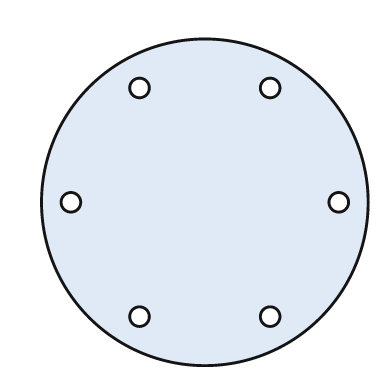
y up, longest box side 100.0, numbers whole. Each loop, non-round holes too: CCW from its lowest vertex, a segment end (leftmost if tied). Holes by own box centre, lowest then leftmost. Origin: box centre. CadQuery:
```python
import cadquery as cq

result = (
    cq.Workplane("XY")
    .moveTo(0.0, 0.0)
    .circle(50.0)
    .moveTo(-20.0, -35.0)
    .circle(3.0)
    .moveTo(20.0, -35.0)
    .circle(3.0)
    .moveTo(-41.0, 0.0)
    .circle(3.0)
    .moveTo(41.0, 0.0)
    .circle(3.0)
    .moveTo(-20.0, 35.0)
    .circle(3.0)
    .moveTo(20.0, 35.0)
    .circle(3.0)
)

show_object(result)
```